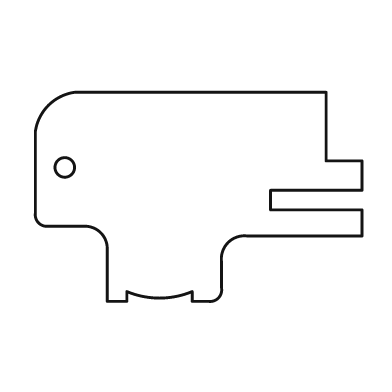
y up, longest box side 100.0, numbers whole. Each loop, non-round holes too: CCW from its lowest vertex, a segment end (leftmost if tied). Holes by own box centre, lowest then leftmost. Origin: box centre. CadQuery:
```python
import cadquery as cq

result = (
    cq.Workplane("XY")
    .moveTo(-28.0, -32.0)
    .lineTo(-22.0, -32.0)
    .lineTo(-22.0, -29.0)
    .threePointArc((-12.0, -31.0), (-2.0, -29.0))
    .lineTo(-2.0, -32.0)
    .lineTo(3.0, -32.0)
    .threePointArc((6.0, -31.0), (7.0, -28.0))
    .lineTo(7.0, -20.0)
    .threePointArc((9.0, -14.0), (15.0, -12.0))
    .lineTo(50.0, -12.0)
    .lineTo(50.0, -4.0)
    .lineTo(22.0, -4.0)
    .lineTo(22.0, 2.0)
    .lineTo(50.0, 2.0)
    .lineTo(50.0, 11.0)
    .lineTo(39.0, 11.0)
    .lineTo(39.0, 32.0)
    .lineTo(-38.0, 32.0)
    .threePointArc((-46.0, 28.0), (-50.0, 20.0))
    .lineTo(-50.0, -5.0)
    .threePointArc((-49.0, -8.0), (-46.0, -9.0))
    .lineTo(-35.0, -9.0)
    .threePointArc((-30.0, -11.0), (-28.0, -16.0))
    .close()
    .moveTo(-41.0, 9.0)
    .circle(3.0)
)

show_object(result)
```